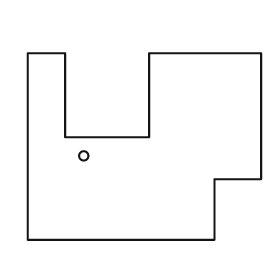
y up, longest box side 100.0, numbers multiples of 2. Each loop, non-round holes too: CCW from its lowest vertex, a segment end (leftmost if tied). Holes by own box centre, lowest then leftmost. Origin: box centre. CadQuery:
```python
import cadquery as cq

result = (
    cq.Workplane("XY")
    .moveTo(-50.0, -40.0)
    .lineTo(30.0, -40.0)
    .lineTo(30.0, -14.0)
    .lineTo(50.0, -14.0)
    .lineTo(50.0, 40.0)
    .lineTo(2.0, 40.0)
    .lineTo(2.0, 4.0)
    .lineTo(-34.0, 4.0)
    .lineTo(-34.0, 40.0)
    .lineTo(-50.0, 40.0)
    .close()
    .moveTo(-26.0, -4.0)
    .circle(2.0)
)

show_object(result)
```